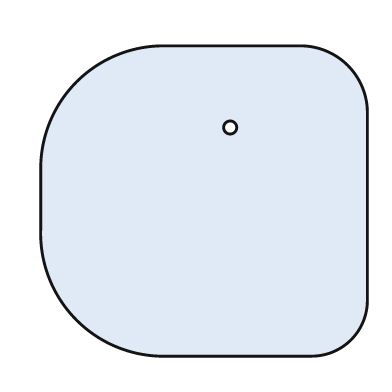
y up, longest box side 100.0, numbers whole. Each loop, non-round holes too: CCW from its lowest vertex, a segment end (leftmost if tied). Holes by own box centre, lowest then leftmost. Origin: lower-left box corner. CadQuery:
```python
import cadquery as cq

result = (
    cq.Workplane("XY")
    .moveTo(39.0, 0.0)
    .lineTo(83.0, 0.0)
    .threePointArc((95.0, 5.0), (100.0, 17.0))
    .lineTo(100.0, 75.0)
    .threePointArc((94.0, 89.0), (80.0, 95.0))
    .lineTo(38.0, 95.0)
    .threePointArc((11.0, 84.0), (0.0, 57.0))
    .lineTo(0.0, 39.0)
    .threePointArc((11.0, 11.0), (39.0, 0.0))
    .close()
    .moveTo(58.0, 70.0)
    .circle(2.0)
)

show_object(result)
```